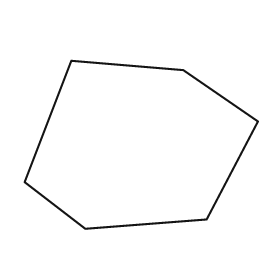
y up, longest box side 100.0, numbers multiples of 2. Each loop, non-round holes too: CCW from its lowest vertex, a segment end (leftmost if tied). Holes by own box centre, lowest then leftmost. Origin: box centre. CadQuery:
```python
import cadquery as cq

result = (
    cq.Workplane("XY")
    .moveTo(-24.0, -36.0)
    .lineTo(28.0, -32.0)
    .lineTo(50.0, 10.0)
    .lineTo(18.0, 32.0)
    .lineTo(-30.0, 36.0)
    .lineTo(-50.0, -16.0)
    .close()
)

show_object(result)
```